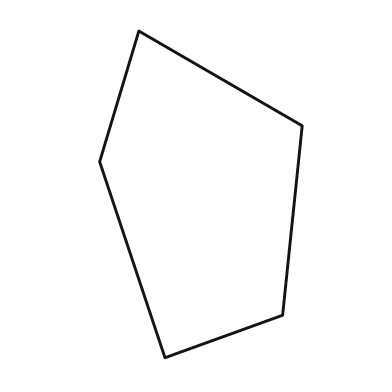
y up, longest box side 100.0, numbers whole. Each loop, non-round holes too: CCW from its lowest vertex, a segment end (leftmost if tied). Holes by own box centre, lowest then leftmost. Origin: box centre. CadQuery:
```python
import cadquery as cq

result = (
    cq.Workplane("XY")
    .moveTo(-11.0, -50.0)
    .lineTo(25.0, -37.0)
    .lineTo(31.0, 21.0)
    .lineTo(-19.0, 50.0)
    .lineTo(-31.0, 10.0)
    .close()
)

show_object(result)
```